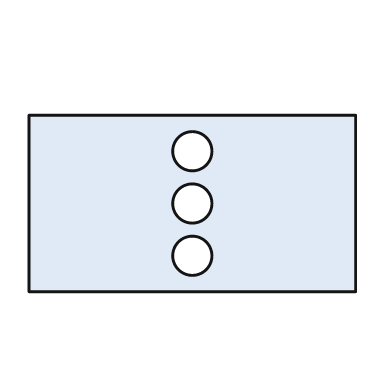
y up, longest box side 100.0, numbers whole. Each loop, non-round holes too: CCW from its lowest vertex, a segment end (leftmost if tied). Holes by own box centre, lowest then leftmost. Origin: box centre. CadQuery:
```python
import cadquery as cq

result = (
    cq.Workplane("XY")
    .moveTo(-50.0, -27.0)
    .lineTo(50.0, -27.0)
    .lineTo(50.0, 27.0)
    .lineTo(-50.0, 27.0)
    .close()
    .moveTo(0.0, -16.0)
    .circle(6.0)
    .moveTo(0.0, 0.0)
    .circle(6.0)
    .moveTo(0.0, 16.0)
    .circle(6.0)
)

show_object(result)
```